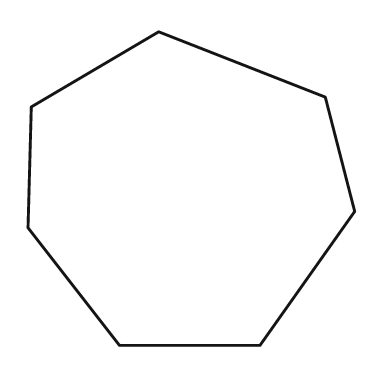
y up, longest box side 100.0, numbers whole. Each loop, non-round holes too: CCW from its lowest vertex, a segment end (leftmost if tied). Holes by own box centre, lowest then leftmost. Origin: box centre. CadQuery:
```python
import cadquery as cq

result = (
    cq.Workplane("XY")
    .moveTo(-22.0, -48.0)
    .lineTo(21.0, -48.0)
    .lineTo(50.0, -7.0)
    .lineTo(41.0, 28.0)
    .lineTo(-10.0, 48.0)
    .lineTo(-49.0, 25.0)
    .lineTo(-50.0, -12.0)
    .close()
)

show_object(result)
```